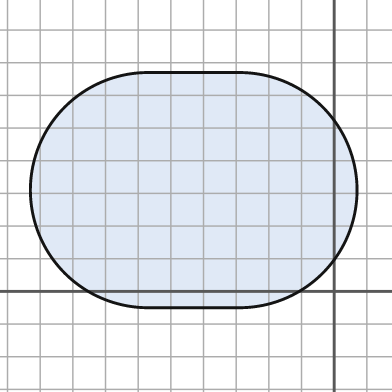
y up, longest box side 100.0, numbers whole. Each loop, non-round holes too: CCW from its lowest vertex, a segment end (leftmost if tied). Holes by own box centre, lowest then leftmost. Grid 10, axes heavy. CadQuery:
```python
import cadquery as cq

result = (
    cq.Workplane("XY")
    .moveTo(-57.0, -5.0)
    .lineTo(-29.0, -5.0)
    .threePointArc((7.0, 31.0), (-29.0, 67.0))
    .lineTo(-57.0, 67.0)
    .threePointArc((-93.0, 31.0), (-57.0, -5.0))
    .close()
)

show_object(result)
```